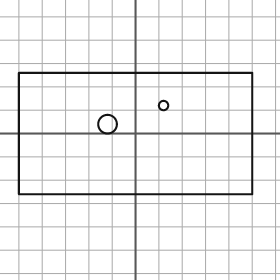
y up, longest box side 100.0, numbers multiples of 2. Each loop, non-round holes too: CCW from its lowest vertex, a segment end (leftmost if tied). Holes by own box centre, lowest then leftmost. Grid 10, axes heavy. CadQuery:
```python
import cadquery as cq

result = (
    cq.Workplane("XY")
    .moveTo(-50.0, -26.0)
    .lineTo(50.0, -26.0)
    .lineTo(50.0, 26.0)
    .lineTo(-50.0, 26.0)
    .close()
    .moveTo(-12.0, 4.0)
    .circle(4.0)
    .moveTo(12.0, 12.0)
    .circle(2.0)
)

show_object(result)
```